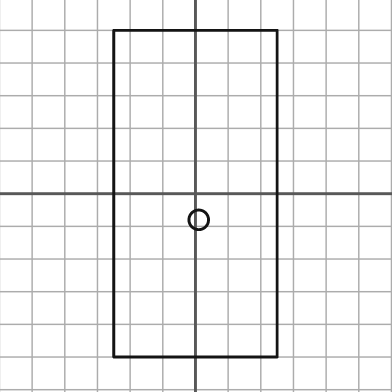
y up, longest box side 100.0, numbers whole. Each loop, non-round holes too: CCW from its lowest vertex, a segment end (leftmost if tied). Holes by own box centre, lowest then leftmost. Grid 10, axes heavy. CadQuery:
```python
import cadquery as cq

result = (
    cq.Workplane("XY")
    .moveTo(-25.0, -50.0)
    .lineTo(25.0, -50.0)
    .lineTo(25.0, 50.0)
    .lineTo(-25.0, 50.0)
    .close()
    .moveTo(1.0, -8.0)
    .circle(3.0)
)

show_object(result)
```